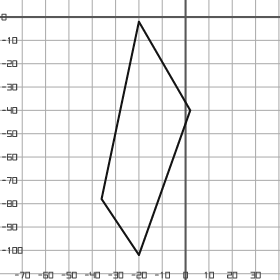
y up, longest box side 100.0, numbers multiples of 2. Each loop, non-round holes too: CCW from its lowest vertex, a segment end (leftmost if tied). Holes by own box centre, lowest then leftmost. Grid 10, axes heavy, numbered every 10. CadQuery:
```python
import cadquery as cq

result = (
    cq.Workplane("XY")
    .moveTo(-20.0, -102.0)
    .lineTo(2.0, -40.0)
    .lineTo(-20.0, -2.0)
    .lineTo(-36.0, -78.0)
    .close()
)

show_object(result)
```